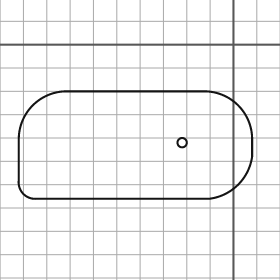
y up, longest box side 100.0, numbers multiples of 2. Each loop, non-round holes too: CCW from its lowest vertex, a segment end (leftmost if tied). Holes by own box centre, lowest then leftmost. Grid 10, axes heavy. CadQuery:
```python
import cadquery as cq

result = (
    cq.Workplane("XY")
    .moveTo(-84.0, -66.0)
    .lineTo(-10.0, -66.0)
    .threePointArc((2.0, -60.0), (8.0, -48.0))
    .lineTo(8.0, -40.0)
    .threePointArc((2.0, -26.0), (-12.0, -20.0))
    .lineTo(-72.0, -20.0)
    .threePointArc((-86.0, -26.0), (-92.0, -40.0))
    .lineTo(-92.0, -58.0)
    .threePointArc((-90.0, -64.0), (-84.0, -66.0))
    .close()
    .moveTo(-22.0, -42.0)
    .circle(2.0)
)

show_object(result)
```